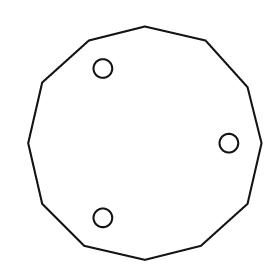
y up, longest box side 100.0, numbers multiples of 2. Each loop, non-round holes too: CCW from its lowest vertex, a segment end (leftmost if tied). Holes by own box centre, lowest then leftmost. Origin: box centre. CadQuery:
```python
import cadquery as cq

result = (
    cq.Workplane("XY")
    .moveTo(0.0, -50.0)
    .lineTo(24.0, -44.0)
    .lineTo(44.0, -26.0)
    .lineTo(50.0, 0.0)
    .lineTo(44.0, 24.0)
    .lineTo(26.0, 44.0)
    .lineTo(0.0, 50.0)
    .lineTo(-24.0, 44.0)
    .lineTo(-44.0, 26.0)
    .lineTo(-50.0, 0.0)
    .lineTo(-44.0, -26.0)
    .lineTo(-26.0, -44.0)
    .close()
    .moveTo(-18.0, -32.0)
    .circle(4.0)
    .moveTo(36.0, 0.0)
    .circle(4.0)
    .moveTo(-18.0, 32.0)
    .circle(4.0)
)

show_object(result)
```